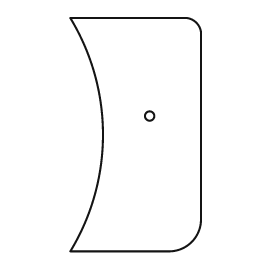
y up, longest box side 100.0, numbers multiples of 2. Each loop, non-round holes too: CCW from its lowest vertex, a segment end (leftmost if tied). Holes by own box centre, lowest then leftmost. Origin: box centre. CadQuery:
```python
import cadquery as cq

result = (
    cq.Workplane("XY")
    .moveTo(-28.0, -50.0)
    .lineTo(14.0, -50.0)
    .threePointArc((24.0, -46.0), (28.0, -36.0))
    .lineTo(28.0, 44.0)
    .threePointArc((26.0, 48.0), (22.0, 50.0))
    .lineTo(-28.0, 50.0)
    .threePointArc((-14.0, 0.0), (-28.0, -50.0))
    .close()
    .moveTo(6.0, 8.0)
    .circle(2.0)
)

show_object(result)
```